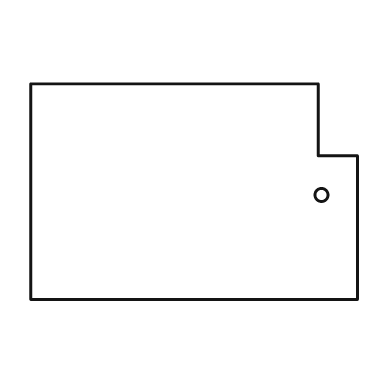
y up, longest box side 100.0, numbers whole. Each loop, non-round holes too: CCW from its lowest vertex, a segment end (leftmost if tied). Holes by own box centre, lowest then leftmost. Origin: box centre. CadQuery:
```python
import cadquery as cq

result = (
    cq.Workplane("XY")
    .moveTo(-50.0, -33.0)
    .lineTo(50.0, -33.0)
    .lineTo(50.0, 11.0)
    .lineTo(38.0, 11.0)
    .lineTo(38.0, 33.0)
    .lineTo(-50.0, 33.0)
    .close()
    .moveTo(39.0, -1.0)
    .circle(2.0)
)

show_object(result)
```